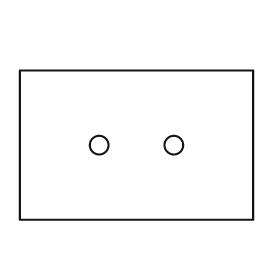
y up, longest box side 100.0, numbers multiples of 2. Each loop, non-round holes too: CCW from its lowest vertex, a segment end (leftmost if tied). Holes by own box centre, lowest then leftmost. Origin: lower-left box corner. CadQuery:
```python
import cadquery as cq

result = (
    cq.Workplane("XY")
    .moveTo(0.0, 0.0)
    .lineTo(100.0, 0.0)
    .lineTo(100.0, 64.0)
    .lineTo(0.0, 64.0)
    .close()
    .moveTo(34.0, 32.0)
    .circle(4.0)
    .moveTo(66.0, 32.0)
    .circle(4.0)
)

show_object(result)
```